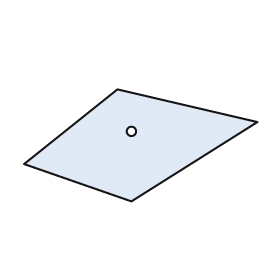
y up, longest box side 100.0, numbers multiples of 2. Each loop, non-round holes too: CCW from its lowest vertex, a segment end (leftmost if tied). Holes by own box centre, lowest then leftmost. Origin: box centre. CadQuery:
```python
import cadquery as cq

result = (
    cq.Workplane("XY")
    .moveTo(-4.0, -24.0)
    .lineTo(50.0, 10.0)
    .lineTo(-10.0, 24.0)
    .lineTo(-50.0, -8.0)
    .close()
    .moveTo(-4.0, 6.0)
    .circle(2.0)
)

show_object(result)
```